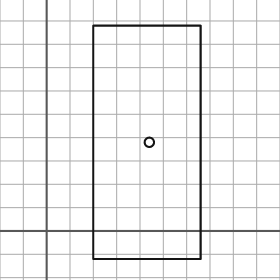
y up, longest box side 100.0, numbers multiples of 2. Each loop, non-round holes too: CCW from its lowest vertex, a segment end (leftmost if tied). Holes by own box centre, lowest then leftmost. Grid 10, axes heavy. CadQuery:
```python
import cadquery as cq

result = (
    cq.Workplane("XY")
    .moveTo(20.0, -12.0)
    .lineTo(66.0, -12.0)
    .lineTo(66.0, 88.0)
    .lineTo(20.0, 88.0)
    .close()
    .moveTo(44.0, 38.0)
    .circle(2.0)
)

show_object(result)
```